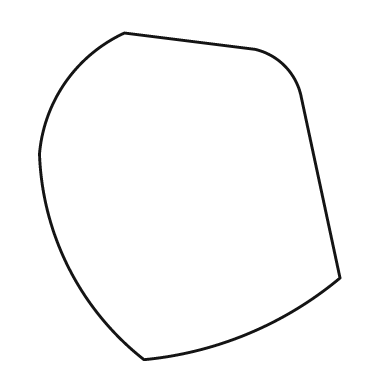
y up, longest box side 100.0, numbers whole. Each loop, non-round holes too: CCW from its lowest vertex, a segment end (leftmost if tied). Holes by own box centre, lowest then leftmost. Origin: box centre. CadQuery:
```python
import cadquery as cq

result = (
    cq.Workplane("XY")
    .moveTo(-14.0, -50.0)
    .threePointArc((18.0, -42.0), (46.0, -25.0))
    .lineTo(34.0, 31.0)
    .threePointArc((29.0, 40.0), (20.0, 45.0))
    .lineTo(-20.0, 50.0)
    .threePointArc((-38.0, 35.0), (-46.0, 13.0))
    .threePointArc((-37.0, -22.0), (-14.0, -50.0))
    .close()
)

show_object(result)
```